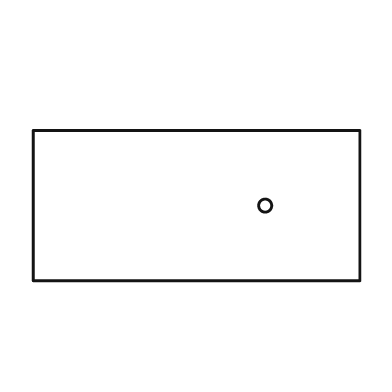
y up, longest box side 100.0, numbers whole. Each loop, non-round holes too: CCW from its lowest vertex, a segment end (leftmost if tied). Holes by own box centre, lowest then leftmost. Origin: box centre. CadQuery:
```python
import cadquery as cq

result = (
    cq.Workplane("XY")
    .moveTo(-50.0, -23.0)
    .lineTo(50.0, -23.0)
    .lineTo(50.0, 23.0)
    .lineTo(-50.0, 23.0)
    .close()
    .moveTo(21.0, 0.0)
    .circle(2.0)
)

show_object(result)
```